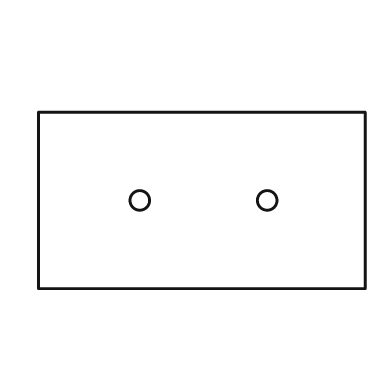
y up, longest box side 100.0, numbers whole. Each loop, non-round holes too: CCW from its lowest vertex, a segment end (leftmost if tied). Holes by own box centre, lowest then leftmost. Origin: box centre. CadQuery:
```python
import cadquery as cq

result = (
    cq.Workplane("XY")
    .moveTo(-50.0, -27.0)
    .lineTo(50.0, -27.0)
    .lineTo(50.0, 27.0)
    .lineTo(-50.0, 27.0)
    .close()
    .moveTo(-19.0, 0.0)
    .circle(3.0)
    .moveTo(20.0, 0.0)
    .circle(3.0)
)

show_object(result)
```